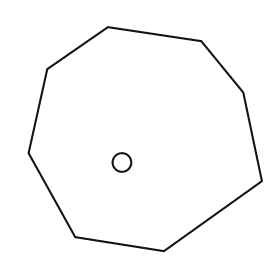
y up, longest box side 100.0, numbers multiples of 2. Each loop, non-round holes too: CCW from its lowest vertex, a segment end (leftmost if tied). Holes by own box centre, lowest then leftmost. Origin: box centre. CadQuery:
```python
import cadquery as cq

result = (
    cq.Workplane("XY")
    .moveTo(8.0, -48.0)
    .lineTo(50.0, -18.0)
    .lineTo(42.0, 20.0)
    .lineTo(24.0, 42.0)
    .lineTo(-16.0, 48.0)
    .lineTo(-42.0, 30.0)
    .lineTo(-50.0, -6.0)
    .lineTo(-30.0, -42.0)
    .close()
    .moveTo(-10.0, -10.0)
    .circle(4.0)
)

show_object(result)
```